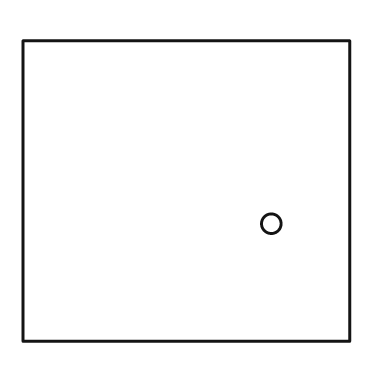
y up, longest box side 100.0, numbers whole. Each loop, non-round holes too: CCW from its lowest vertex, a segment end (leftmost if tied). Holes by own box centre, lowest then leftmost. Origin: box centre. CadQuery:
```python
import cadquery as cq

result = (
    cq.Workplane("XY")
    .moveTo(-50.0, -46.0)
    .lineTo(50.0, -46.0)
    .lineTo(50.0, 46.0)
    .lineTo(-50.0, 46.0)
    .close()
    .moveTo(26.0, -10.0)
    .circle(3.0)
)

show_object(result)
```